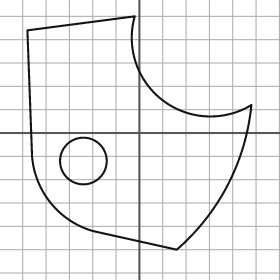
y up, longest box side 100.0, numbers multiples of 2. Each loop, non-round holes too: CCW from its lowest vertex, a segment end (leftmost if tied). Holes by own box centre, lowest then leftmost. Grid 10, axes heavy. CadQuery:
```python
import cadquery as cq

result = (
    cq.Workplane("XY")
    .moveTo(16.0, -50.0)
    .threePointArc((38.0, -22.0), (48.0, 12.0))
    .threePointArc((10.0, 14.0), (-2.0, 50.0))
    .lineTo(-48.0, 44.0)
    .lineTo(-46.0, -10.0)
    .threePointArc((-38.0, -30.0), (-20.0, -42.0))
    .close()
    .moveTo(-24.0, -12.0)
    .circle(10.0)
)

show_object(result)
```